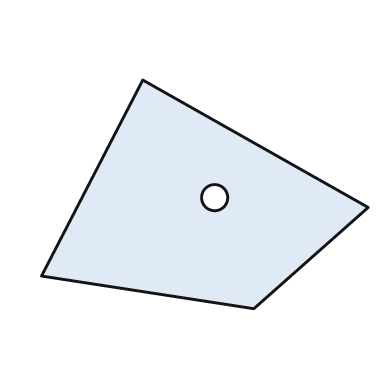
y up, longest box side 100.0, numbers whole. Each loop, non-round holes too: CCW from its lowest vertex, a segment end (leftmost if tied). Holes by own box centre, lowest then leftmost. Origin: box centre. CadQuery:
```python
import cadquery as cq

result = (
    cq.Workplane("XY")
    .moveTo(15.0, -35.0)
    .lineTo(50.0, -4.0)
    .lineTo(-19.0, 35.0)
    .lineTo(-50.0, -25.0)
    .close()
    .moveTo(3.0, -1.0)
    .circle(4.0)
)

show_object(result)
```